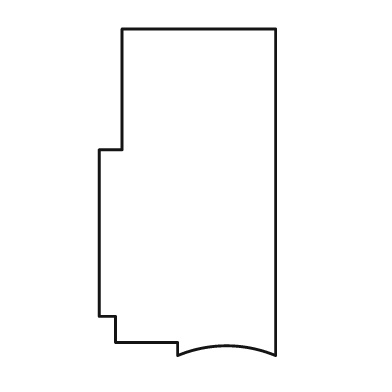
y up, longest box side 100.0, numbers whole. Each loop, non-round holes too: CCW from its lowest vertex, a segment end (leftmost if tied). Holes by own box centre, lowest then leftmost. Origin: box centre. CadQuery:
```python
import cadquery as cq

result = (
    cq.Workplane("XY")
    .moveTo(-3.0, -50.0)
    .threePointArc((12.0, -47.0), (27.0, -50.0))
    .lineTo(27.0, 50.0)
    .lineTo(-20.0, 50.0)
    .lineTo(-20.0, 13.0)
    .lineTo(-27.0, 13.0)
    .lineTo(-27.0, -38.0)
    .lineTo(-22.0, -38.0)
    .lineTo(-22.0, -46.0)
    .lineTo(-3.0, -46.0)
    .close()
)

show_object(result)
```